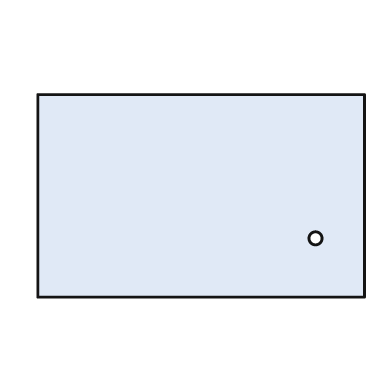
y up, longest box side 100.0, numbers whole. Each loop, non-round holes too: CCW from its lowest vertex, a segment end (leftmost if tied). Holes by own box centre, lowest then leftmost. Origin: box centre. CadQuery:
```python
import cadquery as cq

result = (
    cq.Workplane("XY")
    .moveTo(-50.0, -31.0)
    .lineTo(50.0, -31.0)
    .lineTo(50.0, 31.0)
    .lineTo(-50.0, 31.0)
    .close()
    .moveTo(35.0, -13.0)
    .circle(2.0)
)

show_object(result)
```